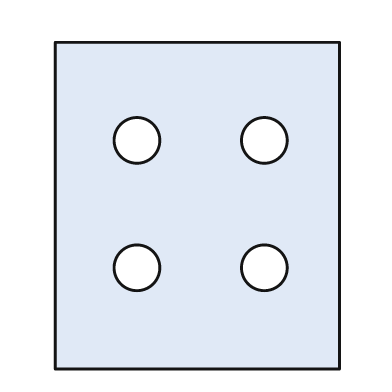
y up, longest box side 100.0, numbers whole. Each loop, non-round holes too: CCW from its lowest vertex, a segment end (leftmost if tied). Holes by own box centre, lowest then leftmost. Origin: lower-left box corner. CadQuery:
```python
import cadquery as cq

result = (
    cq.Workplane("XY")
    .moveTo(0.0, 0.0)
    .lineTo(87.0, 0.0)
    .lineTo(87.0, 100.0)
    .lineTo(0.0, 100.0)
    .close()
    .moveTo(25.0, 31.0)
    .circle(7.0)
    .moveTo(64.0, 31.0)
    .circle(7.0)
    .moveTo(25.0, 70.0)
    .circle(7.0)
    .moveTo(64.0, 70.0)
    .circle(7.0)
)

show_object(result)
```